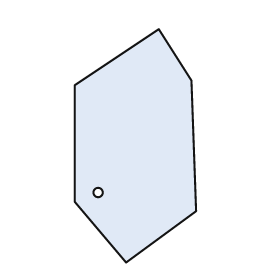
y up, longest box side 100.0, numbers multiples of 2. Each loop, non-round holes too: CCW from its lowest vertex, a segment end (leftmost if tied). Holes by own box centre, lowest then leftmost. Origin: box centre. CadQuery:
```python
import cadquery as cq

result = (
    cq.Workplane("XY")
    .moveTo(-4.0, -50.0)
    .lineTo(26.0, -28.0)
    .lineTo(24.0, 28.0)
    .lineTo(10.0, 50.0)
    .lineTo(-26.0, 26.0)
    .lineTo(-26.0, -24.0)
    .close()
    .moveTo(-16.0, -20.0)
    .circle(2.0)
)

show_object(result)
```